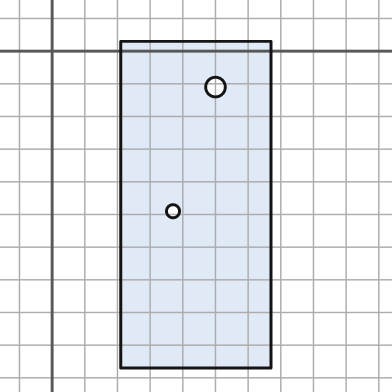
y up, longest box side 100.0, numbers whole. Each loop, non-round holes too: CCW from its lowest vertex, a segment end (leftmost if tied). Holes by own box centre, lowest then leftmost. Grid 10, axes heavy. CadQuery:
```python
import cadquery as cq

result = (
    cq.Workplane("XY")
    .moveTo(21.0, -97.0)
    .lineTo(67.0, -97.0)
    .lineTo(67.0, 3.0)
    .lineTo(21.0, 3.0)
    .close()
    .moveTo(37.0, -49.0)
    .circle(2.0)
    .moveTo(50.0, -11.0)
    .circle(3.0)
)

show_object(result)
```